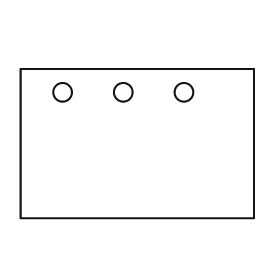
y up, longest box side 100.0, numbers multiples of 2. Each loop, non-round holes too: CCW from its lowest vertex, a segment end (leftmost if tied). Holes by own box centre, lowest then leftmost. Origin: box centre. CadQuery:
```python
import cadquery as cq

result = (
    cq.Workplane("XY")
    .moveTo(-50.0, -32.0)
    .lineTo(50.0, -32.0)
    .lineTo(50.0, 32.0)
    .lineTo(-50.0, 32.0)
    .close()
    .moveTo(-32.0, 22.0)
    .circle(4.0)
    .moveTo(-6.0, 22.0)
    .circle(4.0)
    .moveTo(20.0, 22.0)
    .circle(4.0)
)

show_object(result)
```